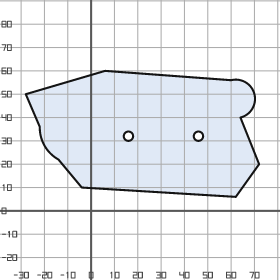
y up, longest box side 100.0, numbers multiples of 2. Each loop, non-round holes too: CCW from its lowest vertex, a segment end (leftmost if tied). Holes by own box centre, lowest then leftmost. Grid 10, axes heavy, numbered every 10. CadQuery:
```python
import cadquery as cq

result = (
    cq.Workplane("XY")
    .moveTo(62.0, 6.0)
    .lineTo(72.0, 20.0)
    .lineTo(64.0, 40.0)
    .threePointArc((70.0, 50.0), (60.0, 56.0))
    .lineTo(6.0, 60.0)
    .lineTo(-28.0, 50.0)
    .lineTo(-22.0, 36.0)
    .threePointArc((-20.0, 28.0), (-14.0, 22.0))
    .lineTo(-4.0, 10.0)
    .close()
    .moveTo(16.0, 32.0)
    .circle(2.0)
    .moveTo(46.0, 32.0)
    .circle(2.0)
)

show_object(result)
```